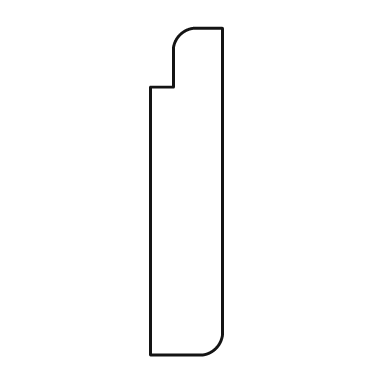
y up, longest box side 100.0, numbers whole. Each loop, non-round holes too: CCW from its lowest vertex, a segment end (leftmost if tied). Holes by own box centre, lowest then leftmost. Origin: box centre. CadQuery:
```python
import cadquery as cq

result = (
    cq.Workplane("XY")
    .moveTo(-11.0, -50.0)
    .lineTo(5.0, -50.0)
    .threePointArc((9.0, -48.0), (11.0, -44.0))
    .lineTo(11.0, 50.0)
    .lineTo(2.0, 50.0)
    .threePointArc((-2.0, 48.0), (-4.0, 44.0))
    .lineTo(-4.0, 32.0)
    .lineTo(-11.0, 32.0)
    .close()
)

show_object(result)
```